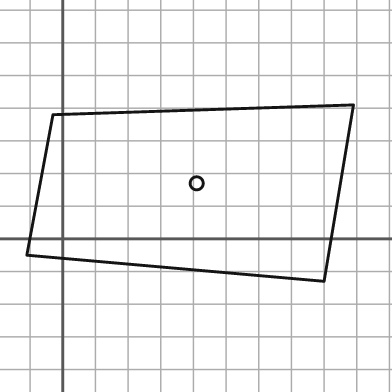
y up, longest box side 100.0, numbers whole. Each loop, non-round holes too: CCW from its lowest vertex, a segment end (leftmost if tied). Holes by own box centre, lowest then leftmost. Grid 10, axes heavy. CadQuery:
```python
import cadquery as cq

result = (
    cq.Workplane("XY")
    .moveTo(80.0, -13.0)
    .lineTo(89.0, 41.0)
    .lineTo(-3.0, 38.0)
    .lineTo(-11.0, -5.0)
    .close()
    .moveTo(41.0, 17.0)
    .circle(2.0)
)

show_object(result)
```